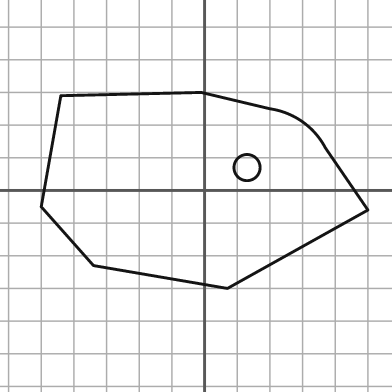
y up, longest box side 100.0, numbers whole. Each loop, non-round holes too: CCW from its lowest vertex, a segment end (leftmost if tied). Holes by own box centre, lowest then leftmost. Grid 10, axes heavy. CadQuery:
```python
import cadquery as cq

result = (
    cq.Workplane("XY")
    .moveTo(7.0, -30.0)
    .lineTo(50.0, -6.0)
    .lineTo(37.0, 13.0)
    .threePointArc((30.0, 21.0), (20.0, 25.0))
    .lineTo(-1.0, 30.0)
    .lineTo(-44.0, 29.0)
    .lineTo(-50.0, -5.0)
    .lineTo(-34.0, -23.0)
    .close()
    .moveTo(13.0, 7.0)
    .circle(4.0)
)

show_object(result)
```